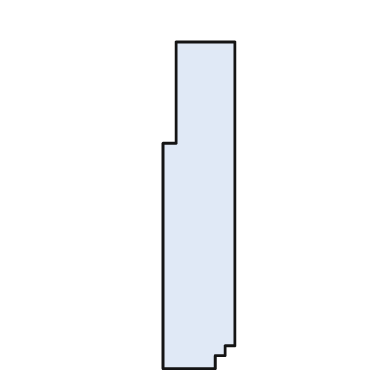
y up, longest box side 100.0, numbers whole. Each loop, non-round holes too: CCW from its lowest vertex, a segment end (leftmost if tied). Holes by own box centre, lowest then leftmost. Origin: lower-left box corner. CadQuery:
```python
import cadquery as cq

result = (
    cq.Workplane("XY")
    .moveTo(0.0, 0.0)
    .lineTo(16.0, 0.0)
    .lineTo(16.0, 4.0)
    .lineTo(19.0, 4.0)
    .lineTo(19.0, 7.0)
    .lineTo(22.0, 7.0)
    .lineTo(22.0, 100.0)
    .lineTo(4.0, 100.0)
    .lineTo(4.0, 69.0)
    .lineTo(0.0, 69.0)
    .close()
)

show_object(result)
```